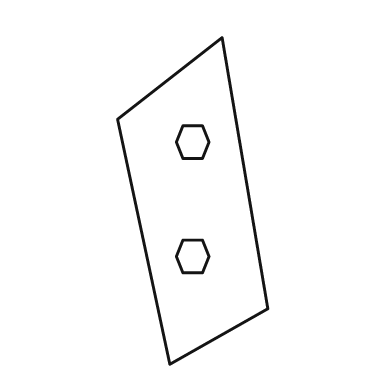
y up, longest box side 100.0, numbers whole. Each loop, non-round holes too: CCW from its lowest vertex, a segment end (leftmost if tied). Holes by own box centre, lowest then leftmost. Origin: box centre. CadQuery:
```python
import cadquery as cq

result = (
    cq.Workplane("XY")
    .moveTo(-7.0, -50.0)
    .lineTo(23.0, -33.0)
    .lineTo(9.0, 50.0)
    .lineTo(-23.0, 25.0)
    .close()
    .moveTo(-3.0, -22.0)
    .lineTo(3.0, -22.0)
    .lineTo(5.0, -17.0)
    .lineTo(3.0, -12.0)
    .lineTo(-3.0, -12.0)
    .lineTo(-5.0, -17.0)
    .close()
    .moveTo(-3.0, 13.0)
    .lineTo(3.0, 13.0)
    .lineTo(5.0, 18.0)
    .lineTo(3.0, 23.0)
    .lineTo(-3.0, 23.0)
    .lineTo(-5.0, 18.0)
    .close()
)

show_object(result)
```